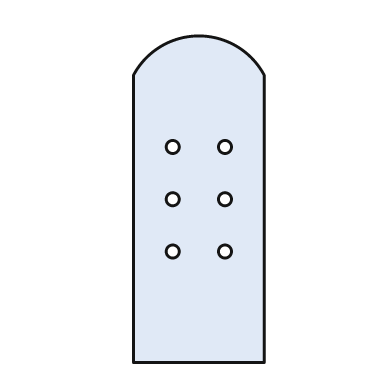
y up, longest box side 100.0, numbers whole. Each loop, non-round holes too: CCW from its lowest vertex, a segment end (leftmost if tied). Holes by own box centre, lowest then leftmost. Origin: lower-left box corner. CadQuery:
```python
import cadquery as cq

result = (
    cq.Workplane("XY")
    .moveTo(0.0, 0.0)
    .lineTo(40.0, 0.0)
    .lineTo(40.0, 88.0)
    .threePointArc((20.0, 100.0), (0.0, 88.0))
    .close()
    .moveTo(12.0, 34.0)
    .circle(2.0)
    .moveTo(28.0, 34.0)
    .circle(2.0)
    .moveTo(12.0, 50.0)
    .circle(2.0)
    .moveTo(28.0, 50.0)
    .circle(2.0)
    .moveTo(12.0, 66.0)
    .circle(2.0)
    .moveTo(28.0, 66.0)
    .circle(2.0)
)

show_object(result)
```